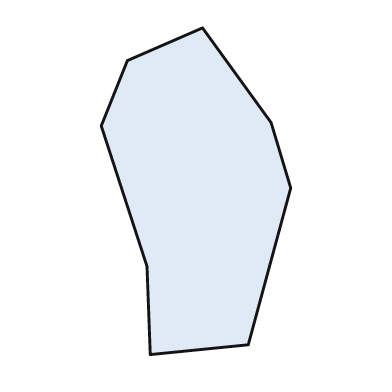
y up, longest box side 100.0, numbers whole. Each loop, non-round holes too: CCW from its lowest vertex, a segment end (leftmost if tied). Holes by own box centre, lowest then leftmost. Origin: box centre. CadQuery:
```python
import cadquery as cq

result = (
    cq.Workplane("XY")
    .moveTo(-14.0, -50.0)
    .lineTo(16.0, -47.0)
    .lineTo(29.0, 1.0)
    .lineTo(23.0, 21.0)
    .lineTo(2.0, 50.0)
    .lineTo(-21.0, 40.0)
    .lineTo(-29.0, 20.0)
    .lineTo(-15.0, -23.0)
    .close()
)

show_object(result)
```